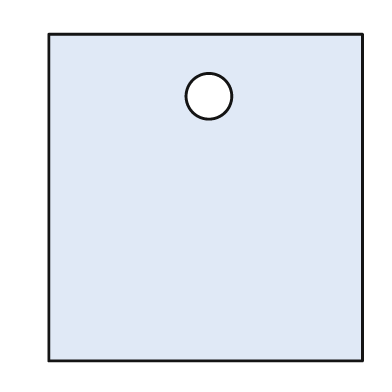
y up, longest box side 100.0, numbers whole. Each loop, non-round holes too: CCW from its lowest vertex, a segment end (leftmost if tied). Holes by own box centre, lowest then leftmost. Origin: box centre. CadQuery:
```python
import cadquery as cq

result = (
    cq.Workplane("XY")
    .moveTo(-48.0, -50.0)
    .lineTo(48.0, -50.0)
    .lineTo(48.0, 50.0)
    .lineTo(-48.0, 50.0)
    .close()
    .moveTo(1.0, 31.0)
    .circle(7.0)
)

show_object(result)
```